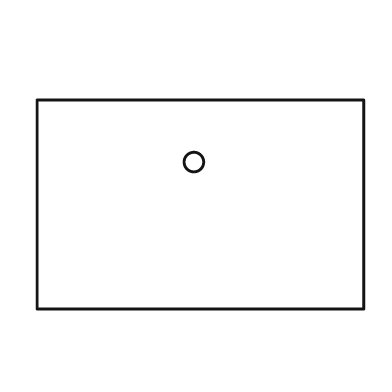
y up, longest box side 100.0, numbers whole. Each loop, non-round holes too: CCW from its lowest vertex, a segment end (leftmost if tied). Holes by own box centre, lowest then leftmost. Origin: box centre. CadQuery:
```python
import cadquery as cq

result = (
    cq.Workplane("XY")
    .moveTo(-50.0, -32.0)
    .lineTo(50.0, -32.0)
    .lineTo(50.0, 32.0)
    .lineTo(-50.0, 32.0)
    .close()
    .moveTo(-2.0, 13.0)
    .circle(3.0)
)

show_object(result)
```